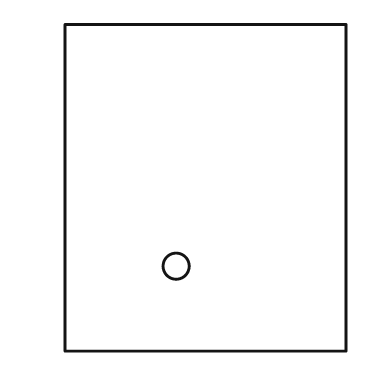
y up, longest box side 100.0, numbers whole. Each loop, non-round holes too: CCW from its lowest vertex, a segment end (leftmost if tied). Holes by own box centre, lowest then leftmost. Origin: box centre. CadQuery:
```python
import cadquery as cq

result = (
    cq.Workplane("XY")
    .moveTo(-43.0, -50.0)
    .lineTo(43.0, -50.0)
    .lineTo(43.0, 50.0)
    .lineTo(-43.0, 50.0)
    .close()
    .moveTo(-9.0, -24.0)
    .circle(4.0)
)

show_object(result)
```